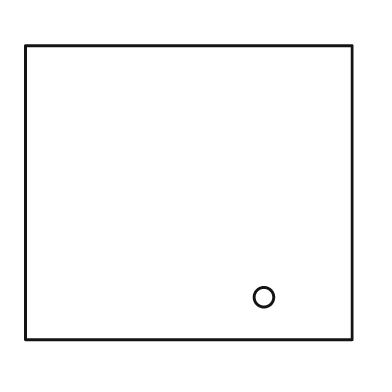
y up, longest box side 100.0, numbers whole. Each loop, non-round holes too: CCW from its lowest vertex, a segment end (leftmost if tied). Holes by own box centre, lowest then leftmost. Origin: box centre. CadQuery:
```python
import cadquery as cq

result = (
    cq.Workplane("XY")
    .moveTo(-50.0, -45.0)
    .lineTo(50.0, -45.0)
    .lineTo(50.0, 45.0)
    .lineTo(-50.0, 45.0)
    .close()
    .moveTo(23.0, -32.0)
    .circle(3.0)
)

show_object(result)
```